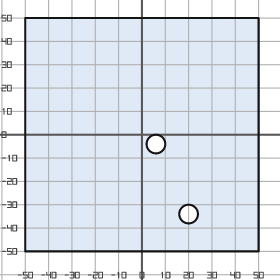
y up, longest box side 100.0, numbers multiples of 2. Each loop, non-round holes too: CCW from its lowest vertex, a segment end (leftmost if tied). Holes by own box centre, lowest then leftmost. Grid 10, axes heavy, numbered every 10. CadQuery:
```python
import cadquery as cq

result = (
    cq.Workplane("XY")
    .moveTo(-50.0, -50.0)
    .lineTo(50.0, -50.0)
    .lineTo(50.0, 50.0)
    .lineTo(-50.0, 50.0)
    .close()
    .moveTo(20.0, -34.0)
    .circle(4.0)
    .moveTo(6.0, -4.0)
    .circle(4.0)
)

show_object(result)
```